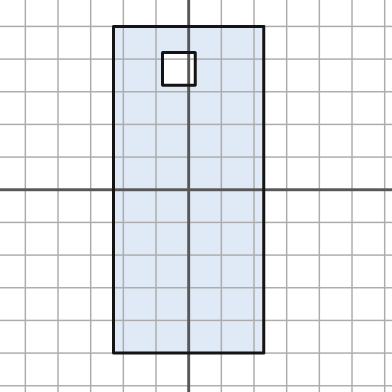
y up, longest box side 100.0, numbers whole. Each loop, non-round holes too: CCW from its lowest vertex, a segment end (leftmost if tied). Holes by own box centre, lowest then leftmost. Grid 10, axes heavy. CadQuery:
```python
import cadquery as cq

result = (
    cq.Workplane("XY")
    .moveTo(-23.0, -50.0)
    .lineTo(23.0, -50.0)
    .lineTo(23.0, 50.0)
    .lineTo(-23.0, 50.0)
    .close()
    .moveTo(-8.0, 32.0)
    .lineTo(2.0, 32.0)
    .lineTo(2.0, 42.0)
    .lineTo(-8.0, 42.0)
    .close()
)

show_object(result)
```